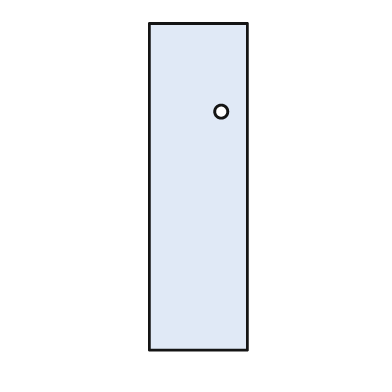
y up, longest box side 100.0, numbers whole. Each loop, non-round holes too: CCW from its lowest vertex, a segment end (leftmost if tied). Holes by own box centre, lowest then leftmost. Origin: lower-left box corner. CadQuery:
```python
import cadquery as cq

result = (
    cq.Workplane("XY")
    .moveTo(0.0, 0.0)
    .lineTo(30.0, 0.0)
    .lineTo(30.0, 100.0)
    .lineTo(0.0, 100.0)
    .close()
    .moveTo(22.0, 73.0)
    .circle(2.0)
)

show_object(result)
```